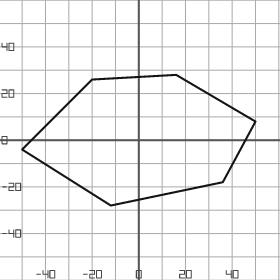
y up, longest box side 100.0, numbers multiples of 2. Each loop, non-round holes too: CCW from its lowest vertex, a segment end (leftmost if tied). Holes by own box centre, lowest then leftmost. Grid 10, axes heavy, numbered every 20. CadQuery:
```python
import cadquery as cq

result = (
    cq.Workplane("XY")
    .moveTo(-12.0, -28.0)
    .lineTo(36.0, -18.0)
    .lineTo(50.0, 8.0)
    .lineTo(16.0, 28.0)
    .lineTo(-20.0, 26.0)
    .lineTo(-50.0, -4.0)
    .close()
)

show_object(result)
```